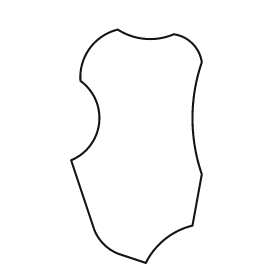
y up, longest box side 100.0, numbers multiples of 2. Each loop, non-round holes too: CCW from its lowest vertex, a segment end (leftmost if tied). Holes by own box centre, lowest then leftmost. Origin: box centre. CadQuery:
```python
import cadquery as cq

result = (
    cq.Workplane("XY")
    .moveTo(4.0, -50.0)
    .threePointArc((12.0, -40.0), (24.0, -34.0))
    .lineTo(28.0, -12.0)
    .threePointArc((24.0, 12.0), (28.0, 36.0))
    .threePointArc((24.0, 44.0), (16.0, 48.0))
    .threePointArc((4.0, 46.0), (-8.0, 50.0))
    .threePointArc((-20.0, 42.0), (-24.0, 28.0))
    .threePointArc((-16.0, 10.0), (-28.0, -6.0))
    .lineTo(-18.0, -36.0)
    .threePointArc((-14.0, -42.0), (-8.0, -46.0))
    .close()
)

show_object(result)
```